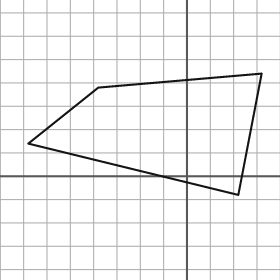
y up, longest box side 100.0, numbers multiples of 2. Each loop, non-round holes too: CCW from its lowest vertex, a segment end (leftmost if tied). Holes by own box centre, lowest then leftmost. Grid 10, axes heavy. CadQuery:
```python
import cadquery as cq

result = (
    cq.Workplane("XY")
    .moveTo(22.0, -8.0)
    .lineTo(32.0, 44.0)
    .lineTo(-38.0, 38.0)
    .lineTo(-68.0, 14.0)
    .close()
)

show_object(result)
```